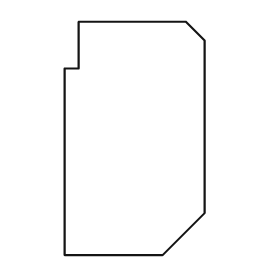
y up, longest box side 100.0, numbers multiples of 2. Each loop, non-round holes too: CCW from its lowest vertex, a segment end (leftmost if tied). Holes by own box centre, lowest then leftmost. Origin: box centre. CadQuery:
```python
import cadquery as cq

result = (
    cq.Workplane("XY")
    .moveTo(-30.0, -50.0)
    .lineTo(12.0, -50.0)
    .lineTo(30.0, -32.0)
    .lineTo(30.0, 42.0)
    .lineTo(22.0, 50.0)
    .lineTo(-24.0, 50.0)
    .lineTo(-24.0, 30.0)
    .lineTo(-30.0, 30.0)
    .close()
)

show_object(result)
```